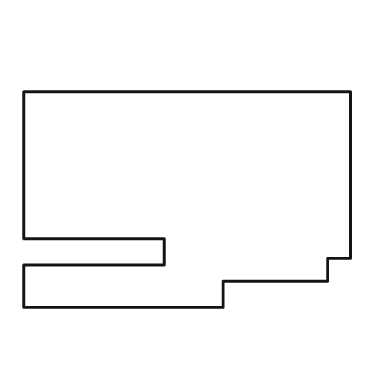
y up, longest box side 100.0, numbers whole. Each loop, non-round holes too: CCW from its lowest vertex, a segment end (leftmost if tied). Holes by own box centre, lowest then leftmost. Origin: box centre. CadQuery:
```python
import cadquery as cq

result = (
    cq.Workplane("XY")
    .moveTo(-50.0, -33.0)
    .lineTo(11.0, -33.0)
    .lineTo(11.0, -25.0)
    .lineTo(43.0, -25.0)
    .lineTo(43.0, -18.0)
    .lineTo(50.0, -18.0)
    .lineTo(50.0, 33.0)
    .lineTo(-50.0, 33.0)
    .lineTo(-50.0, -12.0)
    .lineTo(-7.0, -12.0)
    .lineTo(-7.0, -20.0)
    .lineTo(-50.0, -20.0)
    .close()
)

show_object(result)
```